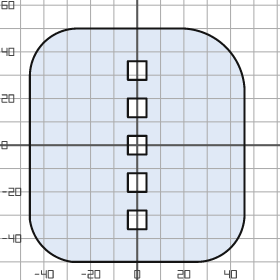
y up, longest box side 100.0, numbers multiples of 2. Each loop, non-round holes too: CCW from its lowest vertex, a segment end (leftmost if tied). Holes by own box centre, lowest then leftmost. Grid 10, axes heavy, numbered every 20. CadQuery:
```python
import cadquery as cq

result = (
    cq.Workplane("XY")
    .moveTo(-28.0, -50.0)
    .lineTo(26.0, -50.0)
    .threePointArc((40.0, -44.0), (46.0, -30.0))
    .lineTo(46.0, 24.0)
    .threePointArc((38.0, 42.0), (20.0, 50.0))
    .lineTo(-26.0, 50.0)
    .threePointArc((-40.0, 44.0), (-46.0, 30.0))
    .lineTo(-46.0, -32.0)
    .threePointArc((-40.0, -44.0), (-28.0, -50.0))
    .close()
    .moveTo(-4.0, -36.0)
    .lineTo(4.0, -36.0)
    .lineTo(4.0, -28.0)
    .lineTo(-4.0, -28.0)
    .close()
    .moveTo(-4.0, -20.0)
    .lineTo(4.0, -20.0)
    .lineTo(4.0, -12.0)
    .lineTo(-4.0, -12.0)
    .close()
    .moveTo(-4.0, -4.0)
    .lineTo(4.0, -4.0)
    .lineTo(4.0, 4.0)
    .lineTo(-4.0, 4.0)
    .close()
    .moveTo(-4.0, 12.0)
    .lineTo(4.0, 12.0)
    .lineTo(4.0, 20.0)
    .lineTo(-4.0, 20.0)
    .close()
    .moveTo(-4.0, 28.0)
    .lineTo(4.0, 28.0)
    .lineTo(4.0, 36.0)
    .lineTo(-4.0, 36.0)
    .close()
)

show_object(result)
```